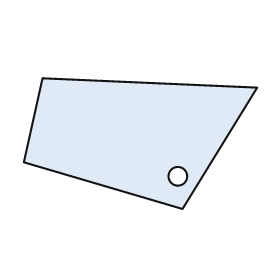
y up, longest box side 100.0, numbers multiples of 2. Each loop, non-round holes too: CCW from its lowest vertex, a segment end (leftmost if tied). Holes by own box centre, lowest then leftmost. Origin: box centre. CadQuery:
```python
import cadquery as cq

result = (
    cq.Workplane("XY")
    .moveTo(18.0, -28.0)
    .lineTo(50.0, 24.0)
    .lineTo(-42.0, 28.0)
    .lineTo(-50.0, -8.0)
    .close()
    .moveTo(16.0, -14.0)
    .circle(4.0)
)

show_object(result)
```